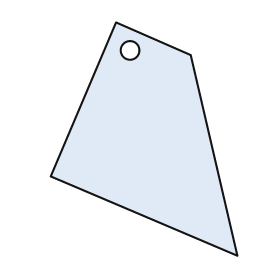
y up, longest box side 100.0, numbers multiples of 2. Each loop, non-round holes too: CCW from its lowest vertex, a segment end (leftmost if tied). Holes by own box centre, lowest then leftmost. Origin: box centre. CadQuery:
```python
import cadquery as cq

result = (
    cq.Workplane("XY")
    .moveTo(40.0, -50.0)
    .lineTo(20.0, 36.0)
    .lineTo(-12.0, 50.0)
    .lineTo(-40.0, -16.0)
    .close()
    .moveTo(-6.0, 38.0)
    .circle(4.0)
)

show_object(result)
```